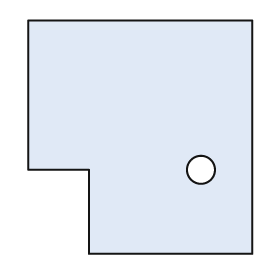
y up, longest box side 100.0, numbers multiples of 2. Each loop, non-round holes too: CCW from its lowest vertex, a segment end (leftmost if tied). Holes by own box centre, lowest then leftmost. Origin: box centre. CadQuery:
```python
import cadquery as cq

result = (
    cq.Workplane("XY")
    .moveTo(-22.0, -50.0)
    .lineTo(48.0, -50.0)
    .lineTo(48.0, 50.0)
    .lineTo(-48.0, 50.0)
    .lineTo(-48.0, -14.0)
    .lineTo(-22.0, -14.0)
    .close()
    .moveTo(26.0, -14.0)
    .circle(6.0)
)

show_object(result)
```